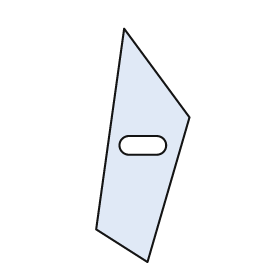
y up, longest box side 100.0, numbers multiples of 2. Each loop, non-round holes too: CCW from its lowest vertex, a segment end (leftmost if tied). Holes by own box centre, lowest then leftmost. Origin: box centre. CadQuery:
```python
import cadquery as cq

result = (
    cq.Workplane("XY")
    .moveTo(2.0, -50.0)
    .lineTo(20.0, 12.0)
    .lineTo(-8.0, 50.0)
    .lineTo(-20.0, -36.0)
    .close()
    .moveTo(-6.0, -4.0)
    .lineTo(6.0, -4.0)
    .threePointArc((10.0, 0.0), (6.0, 4.0))
    .lineTo(-6.0, 4.0)
    .threePointArc((-10.0, 0.0), (-6.0, -4.0))
    .close()
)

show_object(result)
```